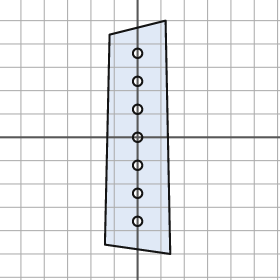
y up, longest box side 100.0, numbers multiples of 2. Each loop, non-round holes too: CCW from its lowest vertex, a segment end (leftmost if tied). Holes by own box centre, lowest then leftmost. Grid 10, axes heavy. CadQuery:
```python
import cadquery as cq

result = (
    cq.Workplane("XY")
    .moveTo(14.0, -50.0)
    .lineTo(12.0, 50.0)
    .lineTo(-12.0, 44.0)
    .lineTo(-14.0, -46.0)
    .close()
    .moveTo(0.0, -36.0)
    .circle(2.0)
    .moveTo(0.0, -24.0)
    .circle(2.0)
    .moveTo(0.0, -12.0)
    .circle(2.0)
    .moveTo(0.0, 0.0)
    .circle(2.0)
    .moveTo(0.0, 12.0)
    .circle(2.0)
    .moveTo(0.0, 24.0)
    .circle(2.0)
    .moveTo(0.0, 36.0)
    .circle(2.0)
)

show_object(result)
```